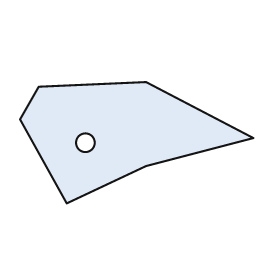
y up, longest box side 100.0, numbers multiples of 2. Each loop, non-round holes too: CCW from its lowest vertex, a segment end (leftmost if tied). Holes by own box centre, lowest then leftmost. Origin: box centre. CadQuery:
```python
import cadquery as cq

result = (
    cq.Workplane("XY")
    .moveTo(-30.0, -26.0)
    .lineTo(4.0, -10.0)
    .lineTo(50.0, 2.0)
    .lineTo(4.0, 26.0)
    .lineTo(-42.0, 24.0)
    .lineTo(-50.0, 10.0)
    .close()
    .moveTo(-22.0, 0.0)
    .circle(4.0)
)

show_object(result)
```